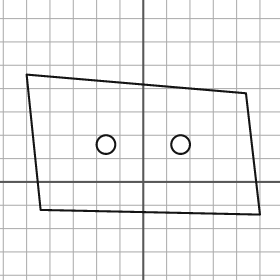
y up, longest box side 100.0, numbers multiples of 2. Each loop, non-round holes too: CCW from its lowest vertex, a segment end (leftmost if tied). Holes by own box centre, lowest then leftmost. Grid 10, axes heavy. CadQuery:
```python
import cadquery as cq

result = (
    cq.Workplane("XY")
    .moveTo(50.0, -14.0)
    .lineTo(44.0, 38.0)
    .lineTo(-50.0, 46.0)
    .lineTo(-44.0, -12.0)
    .close()
    .moveTo(-16.0, 16.0)
    .circle(4.0)
    .moveTo(16.0, 16.0)
    .circle(4.0)
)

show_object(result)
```